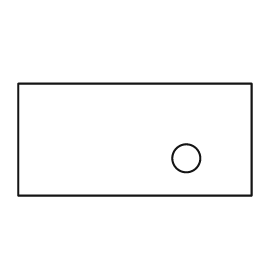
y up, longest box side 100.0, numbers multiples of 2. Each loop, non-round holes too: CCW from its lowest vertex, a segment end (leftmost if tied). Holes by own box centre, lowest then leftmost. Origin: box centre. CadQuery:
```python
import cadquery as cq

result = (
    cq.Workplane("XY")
    .moveTo(-50.0, -24.0)
    .lineTo(50.0, -24.0)
    .lineTo(50.0, 24.0)
    .lineTo(-50.0, 24.0)
    .close()
    .moveTo(22.0, -8.0)
    .circle(6.0)
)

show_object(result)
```